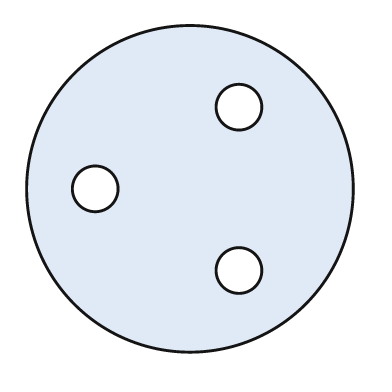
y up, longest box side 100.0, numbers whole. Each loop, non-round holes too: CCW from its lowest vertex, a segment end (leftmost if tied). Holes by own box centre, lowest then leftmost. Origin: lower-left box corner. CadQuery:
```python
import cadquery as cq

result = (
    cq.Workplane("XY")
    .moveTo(50.0, 50.0)
    .circle(50.0)
    .moveTo(65.0, 25.0)
    .circle(7.0)
    .moveTo(21.0, 50.0)
    .circle(7.0)
    .moveTo(65.0, 75.0)
    .circle(7.0)
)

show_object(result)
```